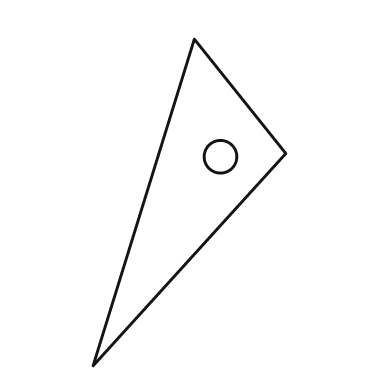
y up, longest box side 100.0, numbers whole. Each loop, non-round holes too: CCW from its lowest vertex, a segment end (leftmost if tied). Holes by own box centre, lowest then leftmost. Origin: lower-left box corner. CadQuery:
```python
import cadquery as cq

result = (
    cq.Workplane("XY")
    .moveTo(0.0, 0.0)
    .lineTo(59.0, 65.0)
    .lineTo(31.0, 100.0)
    .close()
    .moveTo(39.0, 64.0)
    .circle(5.0)
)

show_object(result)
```